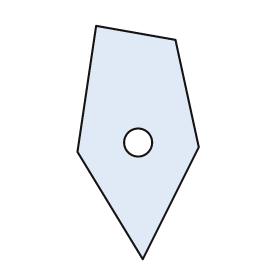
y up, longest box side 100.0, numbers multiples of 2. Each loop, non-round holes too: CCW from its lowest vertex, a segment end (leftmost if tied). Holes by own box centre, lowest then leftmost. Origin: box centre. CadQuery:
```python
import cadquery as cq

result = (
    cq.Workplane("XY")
    .moveTo(2.0, -50.0)
    .lineTo(26.0, -2.0)
    .lineTo(16.0, 44.0)
    .lineTo(-18.0, 50.0)
    .lineTo(-26.0, -4.0)
    .close()
    .moveTo(0.0, 0.0)
    .circle(6.0)
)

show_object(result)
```